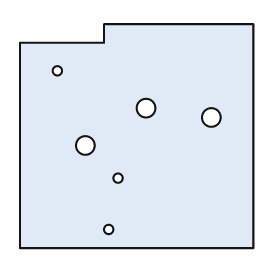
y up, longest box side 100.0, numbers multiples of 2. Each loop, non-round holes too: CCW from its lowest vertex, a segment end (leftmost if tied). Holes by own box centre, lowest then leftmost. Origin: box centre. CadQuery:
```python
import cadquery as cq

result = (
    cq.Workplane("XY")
    .moveTo(-50.0, -48.0)
    .lineTo(50.0, -48.0)
    .lineTo(50.0, 48.0)
    .lineTo(-14.0, 48.0)
    .lineTo(-14.0, 40.0)
    .lineTo(-50.0, 40.0)
    .close()
    .moveTo(-12.0, -40.0)
    .circle(2.0)
    .moveTo(-8.0, -18.0)
    .circle(2.0)
    .moveTo(-22.0, -4.0)
    .circle(4.0)
    .moveTo(32.0, 8.0)
    .circle(4.0)
    .moveTo(4.0, 12.0)
    .circle(4.0)
    .moveTo(-34.0, 28.0)
    .circle(2.0)
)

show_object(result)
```